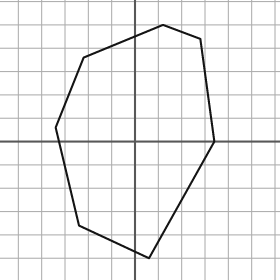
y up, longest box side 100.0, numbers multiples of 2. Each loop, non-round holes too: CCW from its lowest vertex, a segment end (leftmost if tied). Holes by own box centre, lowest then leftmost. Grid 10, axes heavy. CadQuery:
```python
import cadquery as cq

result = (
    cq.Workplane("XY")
    .moveTo(6.0, -50.0)
    .lineTo(34.0, 0.0)
    .lineTo(28.0, 44.0)
    .lineTo(12.0, 50.0)
    .lineTo(-22.0, 36.0)
    .lineTo(-34.0, 6.0)
    .lineTo(-24.0, -36.0)
    .close()
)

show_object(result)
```